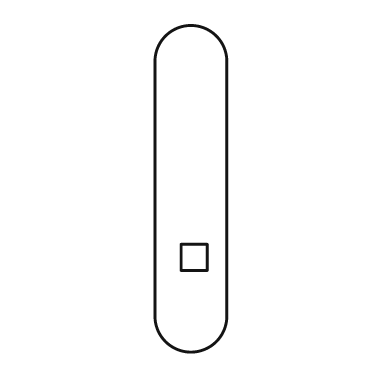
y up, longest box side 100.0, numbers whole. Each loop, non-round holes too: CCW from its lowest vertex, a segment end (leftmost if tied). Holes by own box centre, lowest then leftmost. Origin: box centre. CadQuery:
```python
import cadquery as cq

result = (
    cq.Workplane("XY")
    .moveTo(-11.0, -39.0)
    .threePointArc((0.0, -50.0), (11.0, -39.0))
    .lineTo(11.0, 39.0)
    .threePointArc((0.0, 50.0), (-11.0, 39.0))
    .close()
    .moveTo(-3.0, -25.0)
    .lineTo(5.0, -25.0)
    .lineTo(5.0, -17.0)
    .lineTo(-3.0, -17.0)
    .close()
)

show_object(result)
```